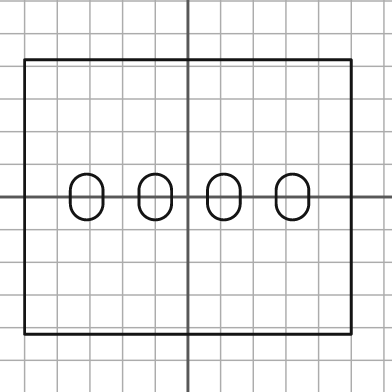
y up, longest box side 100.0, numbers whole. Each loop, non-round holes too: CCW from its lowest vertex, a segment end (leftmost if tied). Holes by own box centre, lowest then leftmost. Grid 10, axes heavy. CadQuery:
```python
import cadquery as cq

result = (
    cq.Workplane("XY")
    .moveTo(-50.0, -42.0)
    .lineTo(50.0, -42.0)
    .lineTo(50.0, 42.0)
    .lineTo(-50.0, 42.0)
    .close()
    .moveTo(-36.0, -2.0)
    .threePointArc((-31.0, -7.0), (-26.0, -2.0))
    .lineTo(-26.0, 2.0)
    .threePointArc((-31.0, 7.0), (-36.0, 2.0))
    .close()
    .moveTo(-15.0, -2.0)
    .threePointArc((-10.0, -7.0), (-5.0, -2.0))
    .lineTo(-5.0, 2.0)
    .threePointArc((-10.0, 7.0), (-15.0, 2.0))
    .close()
    .moveTo(6.0, -2.0)
    .threePointArc((11.0, -7.0), (16.0, -2.0))
    .lineTo(16.0, 2.0)
    .threePointArc((11.0, 7.0), (6.0, 2.0))
    .close()
    .moveTo(27.0, -2.0)
    .threePointArc((32.0, -7.0), (37.0, -2.0))
    .lineTo(37.0, 2.0)
    .threePointArc((32.0, 7.0), (27.0, 2.0))
    .close()
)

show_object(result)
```